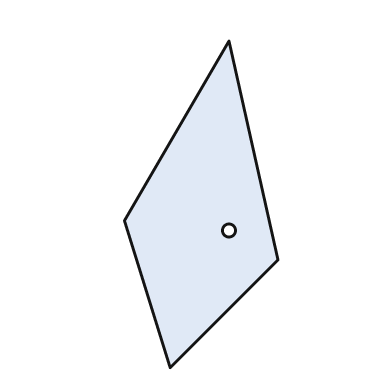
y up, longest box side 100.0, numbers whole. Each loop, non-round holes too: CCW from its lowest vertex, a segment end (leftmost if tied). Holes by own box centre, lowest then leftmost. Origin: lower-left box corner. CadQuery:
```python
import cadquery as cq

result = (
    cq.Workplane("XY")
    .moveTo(14.0, 0.0)
    .lineTo(47.0, 33.0)
    .lineTo(32.0, 100.0)
    .lineTo(0.0, 45.0)
    .close()
    .moveTo(32.0, 42.0)
    .circle(2.0)
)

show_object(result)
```